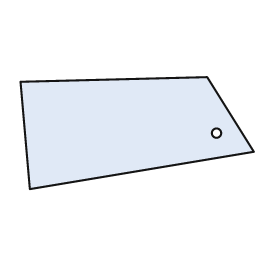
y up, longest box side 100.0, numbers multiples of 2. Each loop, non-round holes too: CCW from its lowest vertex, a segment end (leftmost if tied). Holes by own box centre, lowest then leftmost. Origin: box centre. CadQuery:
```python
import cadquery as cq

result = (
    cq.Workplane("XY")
    .moveTo(-46.0, -24.0)
    .lineTo(50.0, -8.0)
    .lineTo(30.0, 24.0)
    .lineTo(-50.0, 22.0)
    .close()
    .moveTo(34.0, 0.0)
    .circle(2.0)
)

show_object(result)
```